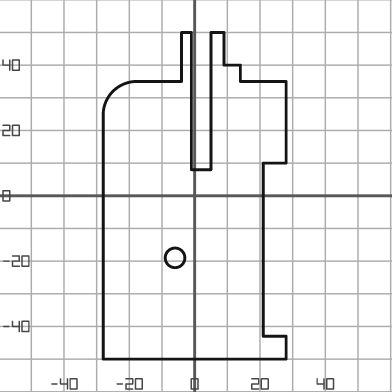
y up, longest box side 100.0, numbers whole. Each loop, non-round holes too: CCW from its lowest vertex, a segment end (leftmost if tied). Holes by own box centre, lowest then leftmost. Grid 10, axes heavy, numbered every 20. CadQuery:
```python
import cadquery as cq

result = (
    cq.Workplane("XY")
    .moveTo(-28.0, -50.0)
    .lineTo(28.0, -50.0)
    .lineTo(28.0, -43.0)
    .lineTo(21.0, -43.0)
    .lineTo(21.0, 10.0)
    .lineTo(28.0, 10.0)
    .lineTo(28.0, 35.0)
    .lineTo(14.0, 35.0)
    .lineTo(14.0, 40.0)
    .lineTo(9.0, 40.0)
    .lineTo(9.0, 50.0)
    .lineTo(5.0, 50.0)
    .lineTo(5.0, 8.0)
    .lineTo(-1.0, 8.0)
    .lineTo(-1.0, 50.0)
    .lineTo(-4.0, 50.0)
    .lineTo(-4.0, 35.0)
    .lineTo(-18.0, 35.0)
    .threePointArc((-25.0, 32.0), (-28.0, 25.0))
    .close()
    .moveTo(-6.0, -19.0)
    .circle(3.0)
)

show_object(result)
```